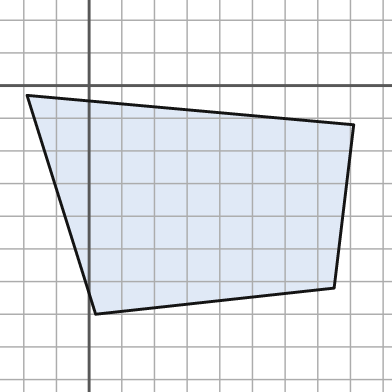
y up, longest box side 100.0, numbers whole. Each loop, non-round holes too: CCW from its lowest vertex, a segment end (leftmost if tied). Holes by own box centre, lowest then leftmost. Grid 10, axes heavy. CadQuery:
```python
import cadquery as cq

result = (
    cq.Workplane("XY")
    .moveTo(2.0, -70.0)
    .lineTo(75.0, -62.0)
    .lineTo(81.0, -12.0)
    .lineTo(-19.0, -3.0)
    .close()
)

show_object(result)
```